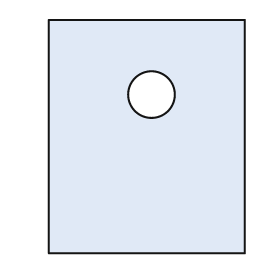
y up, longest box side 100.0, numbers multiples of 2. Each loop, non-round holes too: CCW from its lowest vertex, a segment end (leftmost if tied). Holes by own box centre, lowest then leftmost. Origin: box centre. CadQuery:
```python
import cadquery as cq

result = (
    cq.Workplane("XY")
    .moveTo(-42.0, -50.0)
    .lineTo(42.0, -50.0)
    .lineTo(42.0, 50.0)
    .lineTo(-42.0, 50.0)
    .close()
    .moveTo(2.0, 18.0)
    .circle(10.0)
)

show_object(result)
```